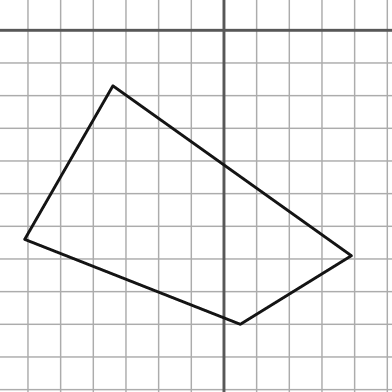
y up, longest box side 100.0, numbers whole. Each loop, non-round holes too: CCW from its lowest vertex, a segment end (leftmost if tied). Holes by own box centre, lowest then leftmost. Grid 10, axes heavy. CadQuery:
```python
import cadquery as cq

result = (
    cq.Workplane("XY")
    .moveTo(5.0, -90.0)
    .lineTo(39.0, -69.0)
    .lineTo(-34.0, -17.0)
    .lineTo(-61.0, -64.0)
    .close()
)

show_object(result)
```